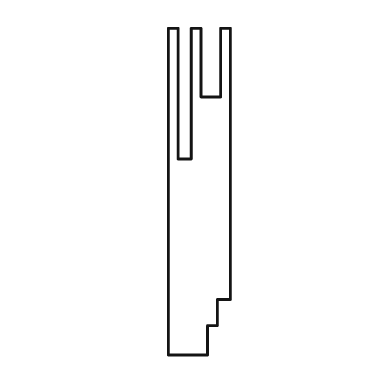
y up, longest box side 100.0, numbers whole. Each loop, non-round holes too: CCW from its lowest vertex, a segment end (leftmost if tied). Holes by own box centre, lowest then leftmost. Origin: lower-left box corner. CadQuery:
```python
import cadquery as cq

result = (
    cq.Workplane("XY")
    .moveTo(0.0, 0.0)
    .lineTo(12.0, 0.0)
    .lineTo(12.0, 9.0)
    .lineTo(15.0, 9.0)
    .lineTo(15.0, 17.0)
    .lineTo(19.0, 17.0)
    .lineTo(19.0, 100.0)
    .lineTo(16.0, 100.0)
    .lineTo(16.0, 79.0)
    .lineTo(10.0, 79.0)
    .lineTo(10.0, 100.0)
    .lineTo(7.0, 100.0)
    .lineTo(7.0, 60.0)
    .lineTo(3.0, 60.0)
    .lineTo(3.0, 100.0)
    .lineTo(0.0, 100.0)
    .close()
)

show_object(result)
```